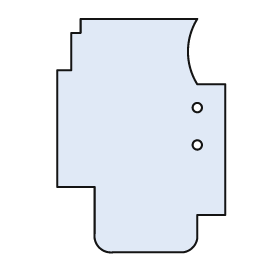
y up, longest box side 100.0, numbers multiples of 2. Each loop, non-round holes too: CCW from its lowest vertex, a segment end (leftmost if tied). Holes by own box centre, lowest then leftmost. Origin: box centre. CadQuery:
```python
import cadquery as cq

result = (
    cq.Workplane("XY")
    .moveTo(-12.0, -50.0)
    .lineTo(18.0, -50.0)
    .threePointArc((22.0, -48.0), (24.0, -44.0))
    .lineTo(24.0, -34.0)
    .lineTo(36.0, -34.0)
    .lineTo(36.0, 22.0)
    .lineTo(24.0, 22.0)
    .threePointArc((20.0, 36.0), (24.0, 50.0))
    .lineTo(-26.0, 50.0)
    .lineTo(-26.0, 44.0)
    .lineTo(-30.0, 44.0)
    .lineTo(-30.0, 28.0)
    .lineTo(-36.0, 28.0)
    .lineTo(-36.0, -22.0)
    .lineTo(-20.0, -22.0)
    .lineTo(-20.0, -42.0)
    .threePointArc((-18.0, -48.0), (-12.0, -50.0))
    .close()
    .moveTo(24.0, -4.0)
    .circle(2.0)
    .moveTo(24.0, 12.0)
    .circle(2.0)
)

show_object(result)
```